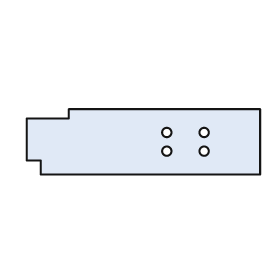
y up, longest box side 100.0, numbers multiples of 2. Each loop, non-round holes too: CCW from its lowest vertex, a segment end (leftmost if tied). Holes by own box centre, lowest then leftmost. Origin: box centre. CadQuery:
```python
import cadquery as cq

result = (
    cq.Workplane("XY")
    .moveTo(-44.0, -14.0)
    .lineTo(50.0, -14.0)
    .lineTo(50.0, 14.0)
    .lineTo(-32.0, 14.0)
    .lineTo(-32.0, 10.0)
    .lineTo(-50.0, 10.0)
    .lineTo(-50.0, -8.0)
    .lineTo(-44.0, -8.0)
    .close()
    .moveTo(10.0, -4.0)
    .circle(2.0)
    .moveTo(26.0, -4.0)
    .circle(2.0)
    .moveTo(10.0, 4.0)
    .circle(2.0)
    .moveTo(26.0, 4.0)
    .circle(2.0)
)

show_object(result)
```